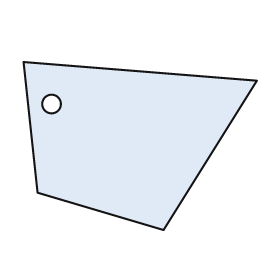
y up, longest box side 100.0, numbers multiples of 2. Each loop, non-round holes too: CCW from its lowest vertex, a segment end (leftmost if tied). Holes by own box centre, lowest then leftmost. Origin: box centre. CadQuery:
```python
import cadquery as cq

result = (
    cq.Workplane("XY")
    .moveTo(10.0, -36.0)
    .lineTo(50.0, 28.0)
    .lineTo(-50.0, 36.0)
    .lineTo(-44.0, -20.0)
    .close()
    .moveTo(-38.0, 18.0)
    .circle(4.0)
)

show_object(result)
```